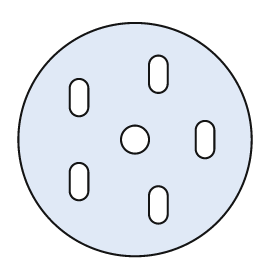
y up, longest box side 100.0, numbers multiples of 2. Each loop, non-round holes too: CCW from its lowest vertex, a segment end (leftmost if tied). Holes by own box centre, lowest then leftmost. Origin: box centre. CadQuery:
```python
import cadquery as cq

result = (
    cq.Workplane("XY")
    .moveTo(0.0, 0.0)
    .circle(50.0)
    .moveTo(6.0, -32.0)
    .threePointArc((10.0, -36.0), (14.0, -32.0))
    .lineTo(14.0, -24.0)
    .threePointArc((10.0, -20.0), (6.0, -24.0))
    .close()
    .moveTo(-28.0, -22.0)
    .threePointArc((-24.0, -26.0), (-20.0, -22.0))
    .lineTo(-20.0, -14.0)
    .threePointArc((-24.0, -10.0), (-28.0, -14.0))
    .close()
    .moveTo(0.0, 0.0)
    .circle(6.0)
    .moveTo(26.0, -4.0)
    .threePointArc((30.0, -8.0), (34.0, -4.0))
    .lineTo(34.0, 4.0)
    .threePointArc((30.0, 8.0), (26.0, 4.0))
    .close()
    .moveTo(-28.0, 14.0)
    .threePointArc((-24.0, 10.0), (-20.0, 14.0))
    .lineTo(-20.0, 22.0)
    .threePointArc((-24.0, 26.0), (-28.0, 22.0))
    .close()
    .moveTo(6.0, 24.0)
    .threePointArc((10.0, 20.0), (14.0, 24.0))
    .lineTo(14.0, 32.0)
    .threePointArc((10.0, 36.0), (6.0, 32.0))
    .close()
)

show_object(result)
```